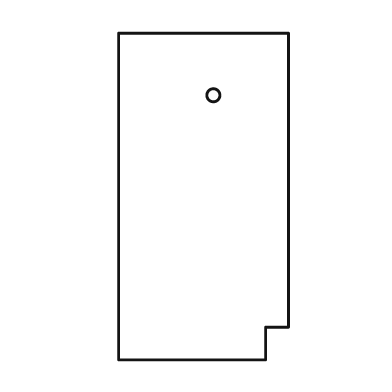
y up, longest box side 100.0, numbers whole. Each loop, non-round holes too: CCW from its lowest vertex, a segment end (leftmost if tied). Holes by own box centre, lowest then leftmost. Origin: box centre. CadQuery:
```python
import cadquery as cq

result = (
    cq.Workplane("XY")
    .moveTo(-26.0, -50.0)
    .lineTo(19.0, -50.0)
    .lineTo(19.0, -40.0)
    .lineTo(26.0, -40.0)
    .lineTo(26.0, 50.0)
    .lineTo(-26.0, 50.0)
    .close()
    .moveTo(3.0, 31.0)
    .circle(2.0)
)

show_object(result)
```